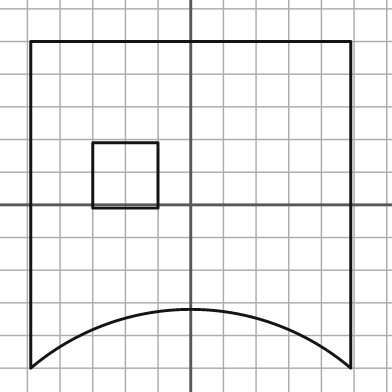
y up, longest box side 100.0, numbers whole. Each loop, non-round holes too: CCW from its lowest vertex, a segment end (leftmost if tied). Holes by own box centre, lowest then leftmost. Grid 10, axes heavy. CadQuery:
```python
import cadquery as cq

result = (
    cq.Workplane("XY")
    .moveTo(-49.0, -50.0)
    .threePointArc((0.0, -32.0), (49.0, -50.0))
    .lineTo(49.0, 50.0)
    .lineTo(-49.0, 50.0)
    .close()
    .moveTo(-30.0, -1.0)
    .lineTo(-10.0, -1.0)
    .lineTo(-10.0, 19.0)
    .lineTo(-30.0, 19.0)
    .close()
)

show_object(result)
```